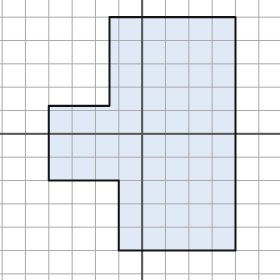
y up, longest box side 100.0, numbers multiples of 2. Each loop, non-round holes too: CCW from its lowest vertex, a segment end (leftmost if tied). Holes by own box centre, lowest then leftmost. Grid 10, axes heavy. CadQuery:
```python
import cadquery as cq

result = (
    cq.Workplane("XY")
    .moveTo(-10.0, -50.0)
    .lineTo(40.0, -50.0)
    .lineTo(40.0, 50.0)
    .lineTo(-14.0, 50.0)
    .lineTo(-14.0, 12.0)
    .lineTo(-40.0, 12.0)
    .lineTo(-40.0, -20.0)
    .lineTo(-10.0, -20.0)
    .close()
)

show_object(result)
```